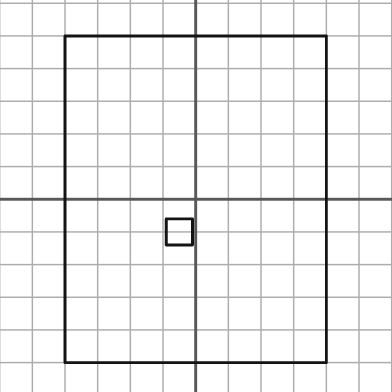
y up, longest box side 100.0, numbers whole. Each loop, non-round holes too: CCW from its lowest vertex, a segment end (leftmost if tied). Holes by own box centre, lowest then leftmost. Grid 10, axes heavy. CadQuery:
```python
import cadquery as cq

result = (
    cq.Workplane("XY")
    .moveTo(-40.0, -50.0)
    .lineTo(40.0, -50.0)
    .lineTo(40.0, 50.0)
    .lineTo(-40.0, 50.0)
    .close()
    .moveTo(-9.0, -14.0)
    .lineTo(-1.0, -14.0)
    .lineTo(-1.0, -6.0)
    .lineTo(-9.0, -6.0)
    .close()
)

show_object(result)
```